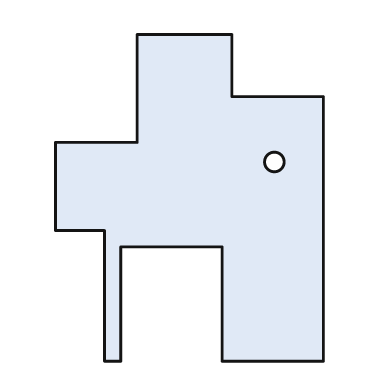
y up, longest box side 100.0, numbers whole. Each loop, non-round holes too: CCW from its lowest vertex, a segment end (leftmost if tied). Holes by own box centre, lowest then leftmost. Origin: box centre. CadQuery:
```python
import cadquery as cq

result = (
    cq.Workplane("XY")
    .moveTo(-26.0, -50.0)
    .lineTo(-21.0, -50.0)
    .lineTo(-21.0, -15.0)
    .lineTo(10.0, -15.0)
    .lineTo(10.0, -50.0)
    .lineTo(41.0, -50.0)
    .lineTo(41.0, 31.0)
    .lineTo(13.0, 31.0)
    .lineTo(13.0, 50.0)
    .lineTo(-16.0, 50.0)
    .lineTo(-16.0, 17.0)
    .lineTo(-41.0, 17.0)
    .lineTo(-41.0, -10.0)
    .lineTo(-26.0, -10.0)
    .close()
    .moveTo(26.0, 11.0)
    .circle(3.0)
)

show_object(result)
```